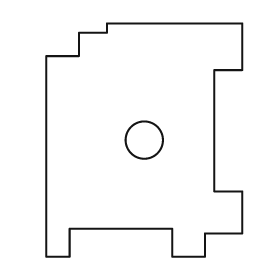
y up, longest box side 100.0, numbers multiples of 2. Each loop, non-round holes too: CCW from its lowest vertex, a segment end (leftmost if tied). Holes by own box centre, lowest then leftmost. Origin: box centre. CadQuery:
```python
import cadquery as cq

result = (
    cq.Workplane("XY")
    .moveTo(-42.0, -50.0)
    .lineTo(-32.0, -50.0)
    .lineTo(-32.0, -38.0)
    .lineTo(12.0, -38.0)
    .lineTo(12.0, -50.0)
    .lineTo(26.0, -50.0)
    .lineTo(26.0, -40.0)
    .lineTo(42.0, -40.0)
    .lineTo(42.0, -22.0)
    .lineTo(30.0, -22.0)
    .lineTo(30.0, 30.0)
    .lineTo(42.0, 30.0)
    .lineTo(42.0, 50.0)
    .lineTo(-16.0, 50.0)
    .lineTo(-16.0, 46.0)
    .lineTo(-28.0, 46.0)
    .lineTo(-28.0, 36.0)
    .lineTo(-42.0, 36.0)
    .close()
    .moveTo(0.0, 0.0)
    .circle(8.0)
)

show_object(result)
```